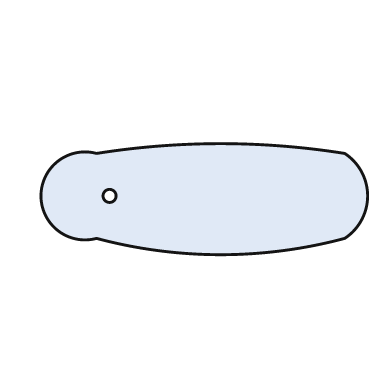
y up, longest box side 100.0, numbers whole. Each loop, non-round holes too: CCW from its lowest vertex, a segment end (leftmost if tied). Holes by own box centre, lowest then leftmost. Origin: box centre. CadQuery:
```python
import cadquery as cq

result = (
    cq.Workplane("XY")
    .moveTo(-33.0, -12.0)
    .threePointArc((5.0, -17.0), (43.0, -12.0))
    .threePointArc((50.0, 1.0), (43.0, 14.0))
    .threePointArc((5.0, 17.0), (-33.0, 14.0))
    .threePointArc((-50.0, 1.0), (-33.0, -12.0))
    .close()
    .moveTo(-29.0, 1.0)
    .circle(2.0)
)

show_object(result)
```